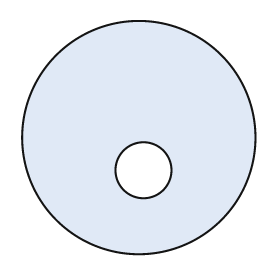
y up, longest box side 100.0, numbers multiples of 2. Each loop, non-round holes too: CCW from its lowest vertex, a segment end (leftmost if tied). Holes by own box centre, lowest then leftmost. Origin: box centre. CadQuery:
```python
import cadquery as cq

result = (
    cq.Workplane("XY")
    .moveTo(0.0, 0.0)
    .circle(50.0)
    .moveTo(2.0, -14.0)
    .circle(12.0)
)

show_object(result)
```